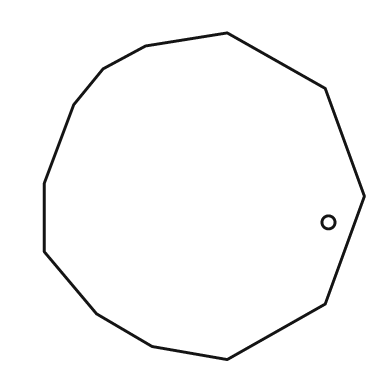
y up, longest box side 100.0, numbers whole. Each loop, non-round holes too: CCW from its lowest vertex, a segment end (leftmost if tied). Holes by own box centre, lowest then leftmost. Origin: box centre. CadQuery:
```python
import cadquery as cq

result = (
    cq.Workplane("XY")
    .moveTo(7.0, -50.0)
    .lineTo(37.0, -33.0)
    .lineTo(49.0, 0.0)
    .lineTo(37.0, 33.0)
    .lineTo(7.0, 50.0)
    .lineTo(-18.0, 46.0)
    .lineTo(-31.0, 39.0)
    .lineTo(-40.0, 28.0)
    .lineTo(-49.0, 4.0)
    .lineTo(-49.0, -17.0)
    .lineTo(-33.0, -36.0)
    .lineTo(-16.0, -46.0)
    .close()
    .moveTo(38.0, -8.0)
    .circle(2.0)
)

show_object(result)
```